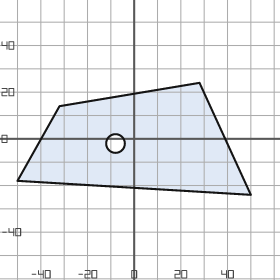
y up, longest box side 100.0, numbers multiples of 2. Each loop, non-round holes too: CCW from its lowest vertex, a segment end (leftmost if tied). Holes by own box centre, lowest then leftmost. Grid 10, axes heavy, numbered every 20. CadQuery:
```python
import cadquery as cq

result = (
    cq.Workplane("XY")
    .moveTo(50.0, -24.0)
    .lineTo(28.0, 24.0)
    .lineTo(-32.0, 14.0)
    .lineTo(-50.0, -18.0)
    .close()
    .moveTo(-8.0, -2.0)
    .circle(4.0)
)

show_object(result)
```